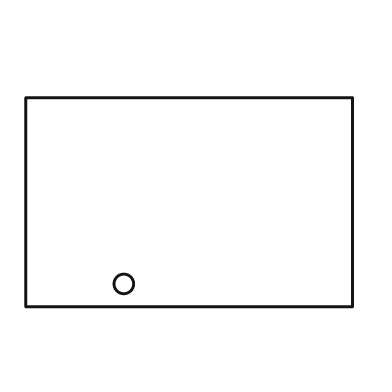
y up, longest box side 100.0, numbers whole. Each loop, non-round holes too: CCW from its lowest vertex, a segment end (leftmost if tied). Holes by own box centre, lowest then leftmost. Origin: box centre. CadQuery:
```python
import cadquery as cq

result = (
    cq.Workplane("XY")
    .moveTo(-50.0, -32.0)
    .lineTo(50.0, -32.0)
    .lineTo(50.0, 32.0)
    .lineTo(-50.0, 32.0)
    .close()
    .moveTo(-20.0, -25.0)
    .circle(3.0)
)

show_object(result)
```